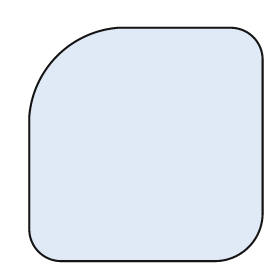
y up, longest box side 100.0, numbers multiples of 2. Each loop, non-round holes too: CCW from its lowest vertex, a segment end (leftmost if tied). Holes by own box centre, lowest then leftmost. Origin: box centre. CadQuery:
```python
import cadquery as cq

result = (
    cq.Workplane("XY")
    .moveTo(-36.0, -50.0)
    .lineTo(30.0, -50.0)
    .threePointArc((44.0, -44.0), (50.0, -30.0))
    .lineTo(50.0, 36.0)
    .threePointArc((46.0, 46.0), (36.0, 50.0))
    .lineTo(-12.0, 50.0)
    .threePointArc((-38.0, 38.0), (-50.0, 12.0))
    .lineTo(-50.0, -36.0)
    .threePointArc((-46.0, -46.0), (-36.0, -50.0))
    .close()
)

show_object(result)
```